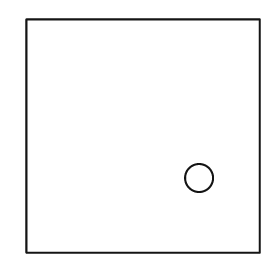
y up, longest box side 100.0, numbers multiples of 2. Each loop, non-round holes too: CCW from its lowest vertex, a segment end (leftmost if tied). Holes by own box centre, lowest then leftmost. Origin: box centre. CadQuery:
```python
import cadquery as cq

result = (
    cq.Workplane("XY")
    .moveTo(-50.0, -50.0)
    .lineTo(50.0, -50.0)
    .lineTo(50.0, 50.0)
    .lineTo(-50.0, 50.0)
    .close()
    .moveTo(24.0, -18.0)
    .circle(6.0)
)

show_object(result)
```